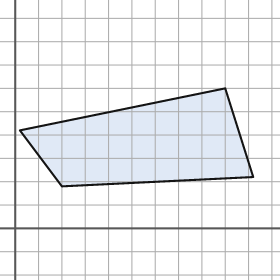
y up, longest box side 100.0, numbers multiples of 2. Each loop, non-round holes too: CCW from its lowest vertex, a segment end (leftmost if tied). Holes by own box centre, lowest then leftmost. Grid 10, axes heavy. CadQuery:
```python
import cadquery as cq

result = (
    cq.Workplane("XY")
    .moveTo(20.0, 18.0)
    .lineTo(102.0, 22.0)
    .lineTo(90.0, 60.0)
    .lineTo(2.0, 42.0)
    .close()
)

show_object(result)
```